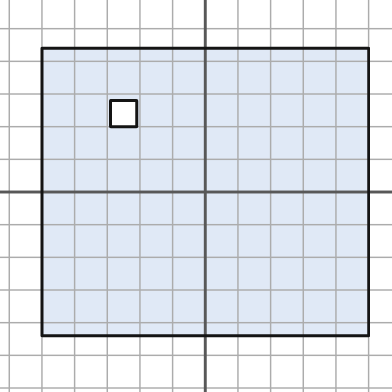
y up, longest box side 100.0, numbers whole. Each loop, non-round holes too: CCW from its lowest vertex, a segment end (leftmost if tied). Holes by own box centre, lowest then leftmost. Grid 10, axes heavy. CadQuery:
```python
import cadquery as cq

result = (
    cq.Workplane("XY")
    .moveTo(-50.0, -44.0)
    .lineTo(50.0, -44.0)
    .lineTo(50.0, 44.0)
    .lineTo(-50.0, 44.0)
    .close()
    .moveTo(-29.0, 20.0)
    .lineTo(-21.0, 20.0)
    .lineTo(-21.0, 28.0)
    .lineTo(-29.0, 28.0)
    .close()
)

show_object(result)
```